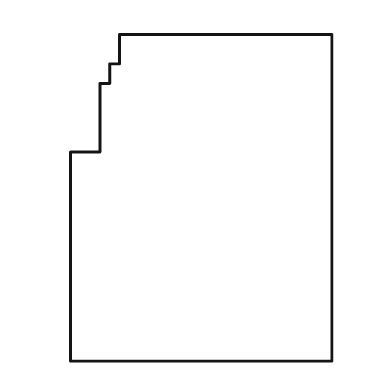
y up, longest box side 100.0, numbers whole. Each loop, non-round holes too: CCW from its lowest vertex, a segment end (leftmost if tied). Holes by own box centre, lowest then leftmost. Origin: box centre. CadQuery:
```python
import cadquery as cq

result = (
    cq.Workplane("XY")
    .moveTo(-40.0, -50.0)
    .lineTo(40.0, -50.0)
    .lineTo(40.0, 50.0)
    .lineTo(-25.0, 50.0)
    .lineTo(-25.0, 41.0)
    .lineTo(-28.0, 41.0)
    .lineTo(-28.0, 35.0)
    .lineTo(-31.0, 35.0)
    .lineTo(-31.0, 14.0)
    .lineTo(-40.0, 14.0)
    .close()
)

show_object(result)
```